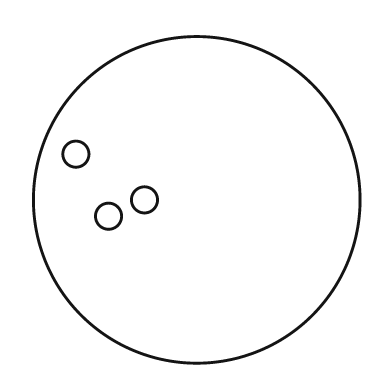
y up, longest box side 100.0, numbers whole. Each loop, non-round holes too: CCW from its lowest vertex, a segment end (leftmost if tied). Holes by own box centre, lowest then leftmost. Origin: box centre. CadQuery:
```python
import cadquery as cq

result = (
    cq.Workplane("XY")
    .moveTo(0.0, 0.0)
    .circle(50.0)
    .moveTo(-27.0, -5.0)
    .circle(4.0)
    .moveTo(-16.0, 0.0)
    .circle(4.0)
    .moveTo(-37.0, 14.0)
    .circle(4.0)
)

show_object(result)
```